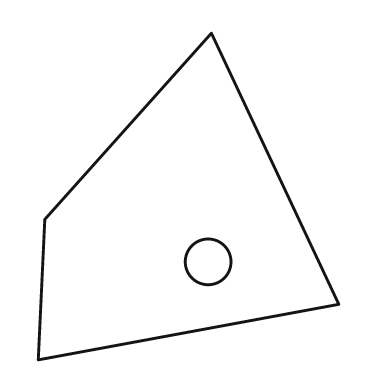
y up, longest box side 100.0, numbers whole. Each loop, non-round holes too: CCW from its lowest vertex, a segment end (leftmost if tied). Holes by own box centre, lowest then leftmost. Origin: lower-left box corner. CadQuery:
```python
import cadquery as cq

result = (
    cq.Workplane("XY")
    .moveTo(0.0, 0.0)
    .lineTo(92.0, 17.0)
    .lineTo(53.0, 100.0)
    .lineTo(2.0, 43.0)
    .close()
    .moveTo(52.0, 30.0)
    .circle(7.0)
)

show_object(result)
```